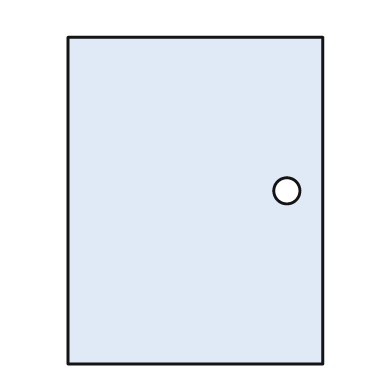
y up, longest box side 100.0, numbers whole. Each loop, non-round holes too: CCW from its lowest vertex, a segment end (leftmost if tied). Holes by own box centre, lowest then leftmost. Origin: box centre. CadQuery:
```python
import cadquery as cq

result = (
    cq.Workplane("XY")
    .moveTo(-39.0, -50.0)
    .lineTo(39.0, -50.0)
    .lineTo(39.0, 50.0)
    .lineTo(-39.0, 50.0)
    .close()
    .moveTo(28.0, 3.0)
    .circle(4.0)
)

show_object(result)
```